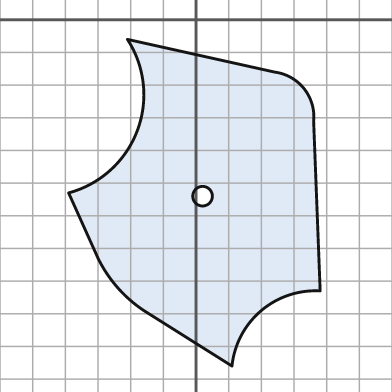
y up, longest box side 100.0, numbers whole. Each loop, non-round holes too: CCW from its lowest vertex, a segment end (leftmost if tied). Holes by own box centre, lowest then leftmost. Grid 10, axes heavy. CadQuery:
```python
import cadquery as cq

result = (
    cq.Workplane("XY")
    .moveTo(11.0, -106.0)
    .threePointArc((20.0, -89.0), (38.0, -83.0))
    .lineTo(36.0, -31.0)
    .threePointArc((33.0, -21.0), (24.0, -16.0))
    .lineTo(-21.0, -6.0)
    .threePointArc((-18.0, -34.0), (-39.0, -53.0))
    .lineTo(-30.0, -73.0)
    .threePointArc((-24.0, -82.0), (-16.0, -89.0))
    .close()
    .moveTo(2.0, -54.0)
    .circle(3.0)
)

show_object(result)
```